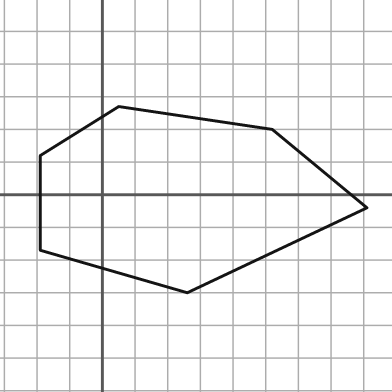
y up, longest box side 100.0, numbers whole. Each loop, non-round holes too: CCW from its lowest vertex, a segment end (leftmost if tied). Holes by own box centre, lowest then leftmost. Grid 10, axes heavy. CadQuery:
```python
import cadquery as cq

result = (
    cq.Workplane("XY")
    .moveTo(26.0, -30.0)
    .lineTo(81.0, -4.0)
    .lineTo(52.0, 20.0)
    .lineTo(5.0, 27.0)
    .lineTo(-19.0, 12.0)
    .lineTo(-19.0, -17.0)
    .close()
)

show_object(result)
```